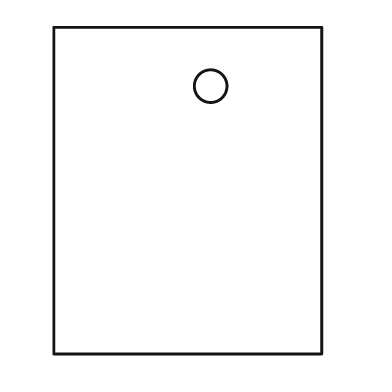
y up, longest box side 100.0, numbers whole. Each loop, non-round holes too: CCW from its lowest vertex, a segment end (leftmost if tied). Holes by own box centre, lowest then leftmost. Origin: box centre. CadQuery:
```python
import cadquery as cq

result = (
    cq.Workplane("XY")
    .moveTo(-41.0, -50.0)
    .lineTo(41.0, -50.0)
    .lineTo(41.0, 50.0)
    .lineTo(-41.0, 50.0)
    .close()
    .moveTo(7.0, 32.0)
    .circle(5.0)
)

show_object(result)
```